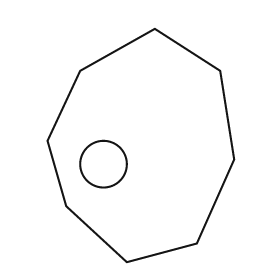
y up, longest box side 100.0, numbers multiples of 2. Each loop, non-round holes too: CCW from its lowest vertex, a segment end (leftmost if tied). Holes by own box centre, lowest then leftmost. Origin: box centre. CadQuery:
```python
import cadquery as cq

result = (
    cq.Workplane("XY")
    .moveTo(-6.0, -50.0)
    .lineTo(24.0, -42.0)
    .lineTo(40.0, -6.0)
    .lineTo(34.0, 32.0)
    .lineTo(6.0, 50.0)
    .lineTo(-26.0, 32.0)
    .lineTo(-40.0, 2.0)
    .lineTo(-32.0, -26.0)
    .close()
    .moveTo(-16.0, -8.0)
    .circle(10.0)
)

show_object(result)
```